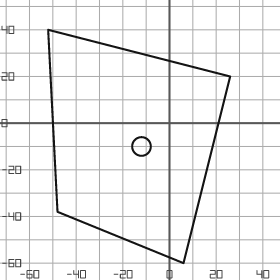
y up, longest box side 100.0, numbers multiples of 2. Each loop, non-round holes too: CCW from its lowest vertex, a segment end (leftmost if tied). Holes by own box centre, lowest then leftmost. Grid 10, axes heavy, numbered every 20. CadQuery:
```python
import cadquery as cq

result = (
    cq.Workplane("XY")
    .moveTo(6.0, -60.0)
    .lineTo(26.0, 20.0)
    .lineTo(-52.0, 40.0)
    .lineTo(-48.0, -38.0)
    .close()
    .moveTo(-12.0, -10.0)
    .circle(4.0)
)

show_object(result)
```